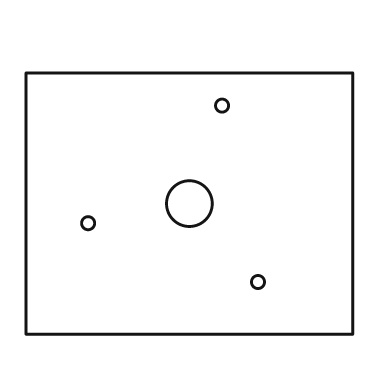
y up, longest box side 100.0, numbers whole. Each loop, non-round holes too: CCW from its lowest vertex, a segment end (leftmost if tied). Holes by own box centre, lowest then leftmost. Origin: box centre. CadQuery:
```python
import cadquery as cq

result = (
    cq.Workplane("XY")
    .moveTo(-50.0, -40.0)
    .lineTo(50.0, -40.0)
    .lineTo(50.0, 40.0)
    .lineTo(-50.0, 40.0)
    .close()
    .moveTo(21.0, -24.0)
    .circle(2.0)
    .moveTo(-31.0, -6.0)
    .circle(2.0)
    .moveTo(0.0, 0.0)
    .circle(7.0)
    .moveTo(10.0, 30.0)
    .circle(2.0)
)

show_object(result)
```